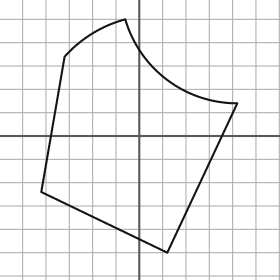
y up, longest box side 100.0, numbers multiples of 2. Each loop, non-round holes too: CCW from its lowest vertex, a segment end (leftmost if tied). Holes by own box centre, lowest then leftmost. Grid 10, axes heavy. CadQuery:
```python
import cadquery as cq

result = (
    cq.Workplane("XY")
    .moveTo(12.0, -50.0)
    .lineTo(42.0, 14.0)
    .threePointArc((12.0, 24.0), (-6.0, 50.0))
    .threePointArc((-20.0, 44.0), (-32.0, 34.0))
    .lineTo(-42.0, -24.0)
    .close()
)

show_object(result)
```